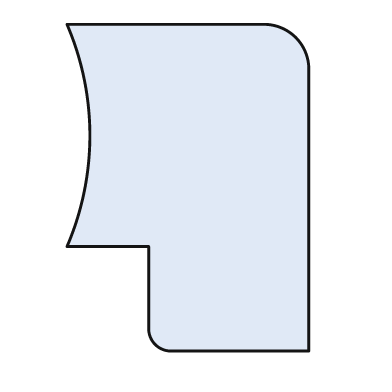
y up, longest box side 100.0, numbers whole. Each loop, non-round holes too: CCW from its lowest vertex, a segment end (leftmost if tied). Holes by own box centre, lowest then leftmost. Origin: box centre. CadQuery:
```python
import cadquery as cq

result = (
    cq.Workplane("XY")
    .moveTo(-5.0, -50.0)
    .lineTo(37.0, -50.0)
    .lineTo(37.0, 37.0)
    .threePointArc((33.0, 46.0), (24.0, 50.0))
    .lineTo(-37.0, 50.0)
    .threePointArc((-30.0, 16.0), (-37.0, -18.0))
    .lineTo(-12.0, -18.0)
    .lineTo(-12.0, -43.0)
    .threePointArc((-10.0, -48.0), (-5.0, -50.0))
    .close()
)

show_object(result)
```